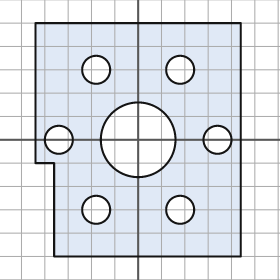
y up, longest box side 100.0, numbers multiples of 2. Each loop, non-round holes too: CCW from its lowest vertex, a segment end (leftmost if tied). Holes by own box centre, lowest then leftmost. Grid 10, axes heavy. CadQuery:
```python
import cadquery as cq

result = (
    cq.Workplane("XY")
    .moveTo(-36.0, -50.0)
    .lineTo(44.0, -50.0)
    .lineTo(44.0, 50.0)
    .lineTo(-44.0, 50.0)
    .lineTo(-44.0, -10.0)
    .lineTo(-36.0, -10.0)
    .close()
    .moveTo(-18.0, -30.0)
    .circle(6.0)
    .moveTo(18.0, -30.0)
    .circle(6.0)
    .moveTo(-34.0, 0.0)
    .circle(6.0)
    .moveTo(0.0, 0.0)
    .circle(16.0)
    .moveTo(34.0, 0.0)
    .circle(6.0)
    .moveTo(-18.0, 30.0)
    .circle(6.0)
    .moveTo(18.0, 30.0)
    .circle(6.0)
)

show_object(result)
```